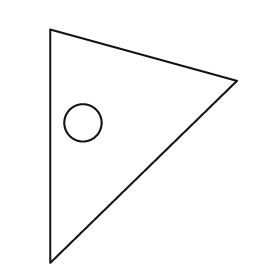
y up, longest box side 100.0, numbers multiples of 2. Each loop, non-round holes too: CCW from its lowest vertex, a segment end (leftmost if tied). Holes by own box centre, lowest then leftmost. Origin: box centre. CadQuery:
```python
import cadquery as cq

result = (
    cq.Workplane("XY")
    .moveTo(-40.0, -50.0)
    .lineTo(40.0, 28.0)
    .lineTo(-40.0, 50.0)
    .close()
    .moveTo(-26.0, 10.0)
    .circle(8.0)
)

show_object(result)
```